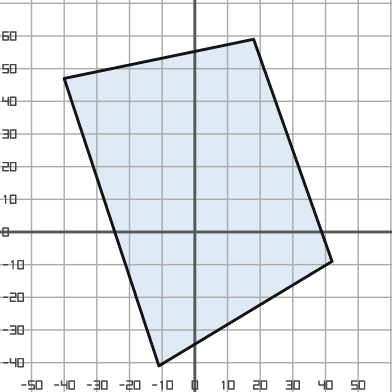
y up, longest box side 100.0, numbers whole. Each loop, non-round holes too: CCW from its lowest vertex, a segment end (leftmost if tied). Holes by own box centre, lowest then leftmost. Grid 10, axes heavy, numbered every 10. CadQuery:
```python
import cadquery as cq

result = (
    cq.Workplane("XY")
    .moveTo(-11.0, -41.0)
    .lineTo(42.0, -9.0)
    .lineTo(18.0, 59.0)
    .lineTo(-40.0, 47.0)
    .close()
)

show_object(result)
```